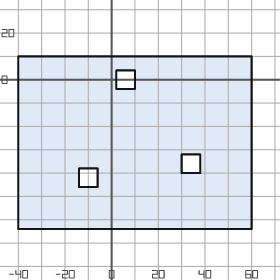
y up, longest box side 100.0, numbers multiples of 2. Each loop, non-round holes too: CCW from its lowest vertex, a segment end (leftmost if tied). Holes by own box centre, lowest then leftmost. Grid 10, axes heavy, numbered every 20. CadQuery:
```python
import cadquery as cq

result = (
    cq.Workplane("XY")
    .moveTo(-40.0, -64.0)
    .lineTo(60.0, -64.0)
    .lineTo(60.0, 10.0)
    .lineTo(-40.0, 10.0)
    .close()
    .moveTo(-14.0, -46.0)
    .lineTo(-6.0, -46.0)
    .lineTo(-6.0, -38.0)
    .lineTo(-14.0, -38.0)
    .close()
    .moveTo(30.0, -40.0)
    .lineTo(38.0, -40.0)
    .lineTo(38.0, -32.0)
    .lineTo(30.0, -32.0)
    .close()
    .moveTo(2.0, -4.0)
    .lineTo(10.0, -4.0)
    .lineTo(10.0, 4.0)
    .lineTo(2.0, 4.0)
    .close()
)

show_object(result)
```